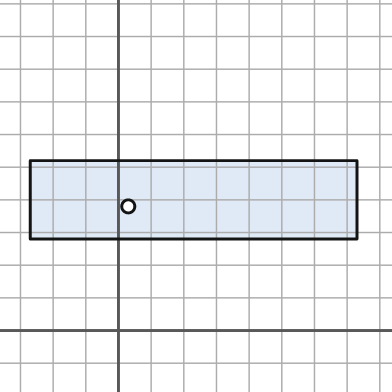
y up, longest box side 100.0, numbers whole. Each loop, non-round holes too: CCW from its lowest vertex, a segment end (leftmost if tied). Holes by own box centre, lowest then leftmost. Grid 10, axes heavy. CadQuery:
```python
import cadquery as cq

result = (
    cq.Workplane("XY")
    .moveTo(-27.0, 28.0)
    .lineTo(73.0, 28.0)
    .lineTo(73.0, 52.0)
    .lineTo(-27.0, 52.0)
    .close()
    .moveTo(3.0, 38.0)
    .circle(2.0)
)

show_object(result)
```